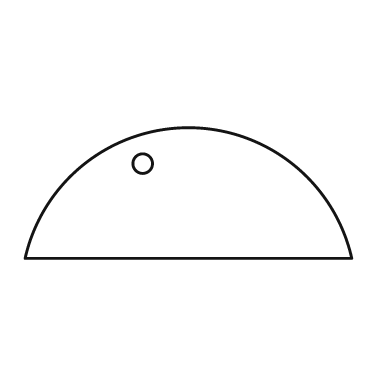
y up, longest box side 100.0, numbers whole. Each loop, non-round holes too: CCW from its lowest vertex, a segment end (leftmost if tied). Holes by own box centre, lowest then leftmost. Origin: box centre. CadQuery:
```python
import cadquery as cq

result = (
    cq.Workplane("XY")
    .moveTo(-50.0, -20.0)
    .lineTo(50.0, -20.0)
    .threePointArc((0.0, 20.0), (-50.0, -20.0))
    .close()
    .moveTo(-14.0, 9.0)
    .circle(3.0)
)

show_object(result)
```